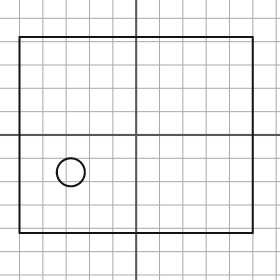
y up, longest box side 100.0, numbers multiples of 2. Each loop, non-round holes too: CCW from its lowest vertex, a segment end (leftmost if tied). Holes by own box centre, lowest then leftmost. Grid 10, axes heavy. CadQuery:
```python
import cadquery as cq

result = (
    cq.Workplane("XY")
    .moveTo(-50.0, -42.0)
    .lineTo(50.0, -42.0)
    .lineTo(50.0, 42.0)
    .lineTo(-50.0, 42.0)
    .close()
    .moveTo(-28.0, -16.0)
    .circle(6.0)
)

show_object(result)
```